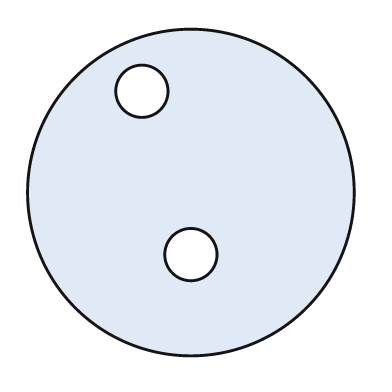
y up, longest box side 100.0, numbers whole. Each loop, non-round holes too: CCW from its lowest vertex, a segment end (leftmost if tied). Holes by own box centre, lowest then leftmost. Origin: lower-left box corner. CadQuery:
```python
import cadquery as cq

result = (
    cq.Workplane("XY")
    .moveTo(50.0, 50.0)
    .circle(50.0)
    .moveTo(50.0, 31.0)
    .circle(8.0)
    .moveTo(35.0, 81.0)
    .circle(8.0)
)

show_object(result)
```